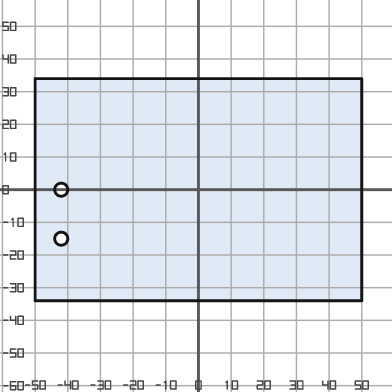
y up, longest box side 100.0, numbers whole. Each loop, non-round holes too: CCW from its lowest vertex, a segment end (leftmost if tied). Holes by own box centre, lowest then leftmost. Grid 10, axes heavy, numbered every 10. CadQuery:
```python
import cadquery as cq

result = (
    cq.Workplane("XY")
    .moveTo(-50.0, -34.0)
    .lineTo(50.0, -34.0)
    .lineTo(50.0, 34.0)
    .lineTo(-50.0, 34.0)
    .close()
    .moveTo(-42.0, -15.0)
    .circle(2.0)
    .moveTo(-42.0, 0.0)
    .circle(2.0)
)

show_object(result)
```